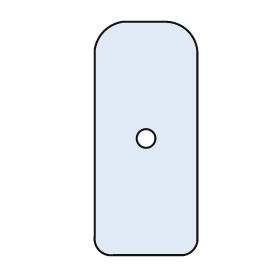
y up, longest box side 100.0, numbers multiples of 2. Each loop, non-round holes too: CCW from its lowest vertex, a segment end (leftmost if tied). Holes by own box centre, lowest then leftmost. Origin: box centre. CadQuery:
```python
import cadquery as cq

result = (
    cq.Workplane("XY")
    .moveTo(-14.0, -50.0)
    .lineTo(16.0, -50.0)
    .threePointArc((20.0, -48.0), (22.0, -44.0))
    .lineTo(22.0, 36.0)
    .threePointArc((18.0, 46.0), (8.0, 50.0))
    .lineTo(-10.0, 50.0)
    .threePointArc((-18.0, 46.0), (-22.0, 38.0))
    .lineTo(-22.0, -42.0)
    .threePointArc((-20.0, -48.0), (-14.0, -50.0))
    .close()
    .moveTo(0.0, 0.0)
    .circle(4.0)
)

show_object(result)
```